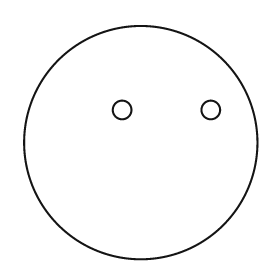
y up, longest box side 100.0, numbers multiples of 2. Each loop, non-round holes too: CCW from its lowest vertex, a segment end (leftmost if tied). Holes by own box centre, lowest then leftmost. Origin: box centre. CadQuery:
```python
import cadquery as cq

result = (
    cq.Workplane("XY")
    .moveTo(0.0, 0.0)
    .circle(50.0)
    .moveTo(-8.0, 14.0)
    .circle(4.0)
    .moveTo(30.0, 14.0)
    .circle(4.0)
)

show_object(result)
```